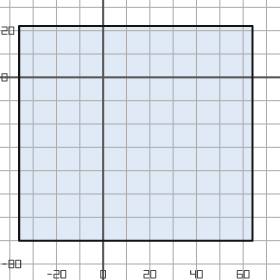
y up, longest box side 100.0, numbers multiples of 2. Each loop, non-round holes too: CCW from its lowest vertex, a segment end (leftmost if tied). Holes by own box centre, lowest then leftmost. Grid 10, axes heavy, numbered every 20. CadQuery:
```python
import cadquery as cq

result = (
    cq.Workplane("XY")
    .moveTo(-36.0, -70.0)
    .lineTo(64.0, -70.0)
    .lineTo(64.0, 22.0)
    .lineTo(-36.0, 22.0)
    .close()
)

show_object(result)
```